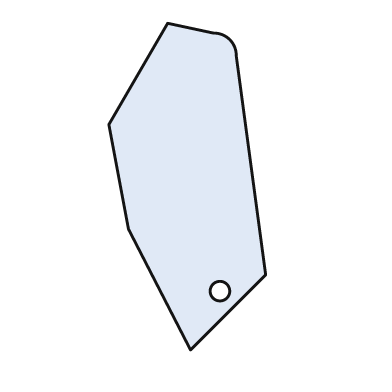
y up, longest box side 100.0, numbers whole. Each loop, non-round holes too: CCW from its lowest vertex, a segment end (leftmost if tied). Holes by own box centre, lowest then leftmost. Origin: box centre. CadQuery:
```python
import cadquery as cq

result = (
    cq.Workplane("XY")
    .moveTo(1.0, -50.0)
    .lineTo(24.0, -27.0)
    .lineTo(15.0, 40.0)
    .threePointArc((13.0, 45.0), (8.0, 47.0))
    .lineTo(-6.0, 50.0)
    .lineTo(-24.0, 19.0)
    .lineTo(-18.0, -13.0)
    .close()
    .moveTo(10.0, -32.0)
    .circle(3.0)
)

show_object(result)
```